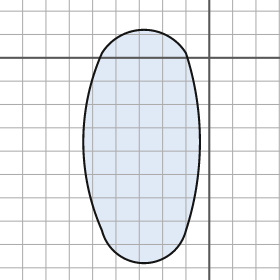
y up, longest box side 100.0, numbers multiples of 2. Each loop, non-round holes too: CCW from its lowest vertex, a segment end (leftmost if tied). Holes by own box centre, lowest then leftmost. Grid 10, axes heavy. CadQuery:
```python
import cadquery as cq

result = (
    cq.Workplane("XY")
    .moveTo(-46.0, -74.0)
    .threePointArc((-28.0, -88.0), (-10.0, -74.0))
    .threePointArc((-4.0, -36.0), (-10.0, 2.0))
    .threePointArc((-28.0, 12.0), (-46.0, 2.0))
    .threePointArc((-54.0, -36.0), (-46.0, -74.0))
    .close()
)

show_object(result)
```